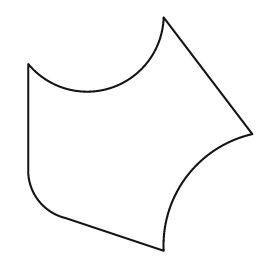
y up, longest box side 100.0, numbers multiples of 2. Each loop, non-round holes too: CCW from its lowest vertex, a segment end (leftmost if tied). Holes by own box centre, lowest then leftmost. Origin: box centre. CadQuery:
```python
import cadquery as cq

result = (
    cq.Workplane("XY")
    .moveTo(10.0, -50.0)
    .threePointArc((20.0, -18.0), (48.0, 0.0))
    .lineTo(10.0, 50.0)
    .threePointArc((-12.0, 20.0), (-48.0, 30.0))
    .lineTo(-48.0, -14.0)
    .threePointArc((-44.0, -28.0), (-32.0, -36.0))
    .close()
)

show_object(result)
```